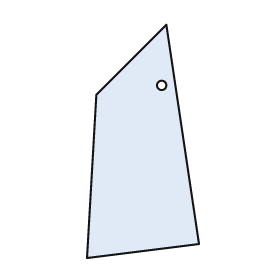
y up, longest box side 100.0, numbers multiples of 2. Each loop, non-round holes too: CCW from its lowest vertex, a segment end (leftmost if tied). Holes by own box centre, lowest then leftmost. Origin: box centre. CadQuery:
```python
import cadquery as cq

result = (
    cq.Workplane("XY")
    .moveTo(-24.0, -50.0)
    .lineTo(24.0, -44.0)
    .lineTo(10.0, 50.0)
    .lineTo(-20.0, 20.0)
    .close()
    .moveTo(8.0, 24.0)
    .circle(2.0)
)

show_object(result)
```